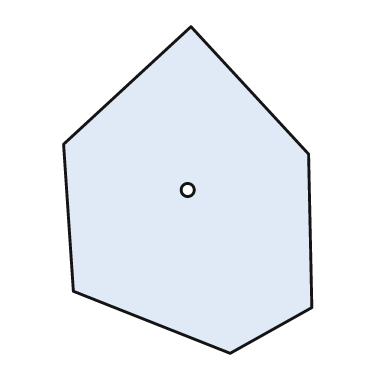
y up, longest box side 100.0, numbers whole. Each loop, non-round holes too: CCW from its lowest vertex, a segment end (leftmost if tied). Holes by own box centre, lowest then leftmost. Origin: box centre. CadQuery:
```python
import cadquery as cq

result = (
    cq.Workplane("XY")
    .moveTo(13.0, -50.0)
    .lineTo(38.0, -36.0)
    .lineTo(37.0, 11.0)
    .lineTo(1.0, 50.0)
    .lineTo(-38.0, 14.0)
    .lineTo(-35.0, -31.0)
    .close()
    .moveTo(0.0, 0.0)
    .circle(2.0)
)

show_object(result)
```